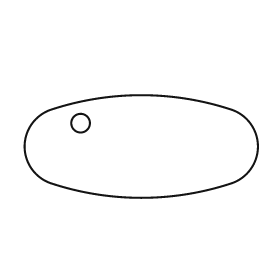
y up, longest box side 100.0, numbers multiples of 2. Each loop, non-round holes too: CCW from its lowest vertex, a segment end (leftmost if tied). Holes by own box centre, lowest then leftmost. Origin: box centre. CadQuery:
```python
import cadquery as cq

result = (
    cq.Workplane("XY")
    .moveTo(-38.0, -16.0)
    .threePointArc((0.0, -22.0), (38.0, -16.0))
    .threePointArc((50.0, 0.0), (38.0, 16.0))
    .threePointArc((0.0, 22.0), (-38.0, 16.0))
    .threePointArc((-50.0, 0.0), (-38.0, -16.0))
    .close()
    .moveTo(-26.0, 10.0)
    .circle(4.0)
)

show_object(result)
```